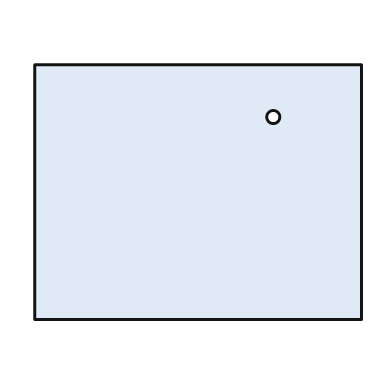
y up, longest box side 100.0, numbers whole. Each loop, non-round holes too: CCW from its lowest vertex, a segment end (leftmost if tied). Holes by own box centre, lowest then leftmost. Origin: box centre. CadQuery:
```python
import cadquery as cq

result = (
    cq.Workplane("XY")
    .moveTo(-50.0, -39.0)
    .lineTo(50.0, -39.0)
    .lineTo(50.0, 39.0)
    .lineTo(-50.0, 39.0)
    .close()
    .moveTo(23.0, 23.0)
    .circle(2.0)
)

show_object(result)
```